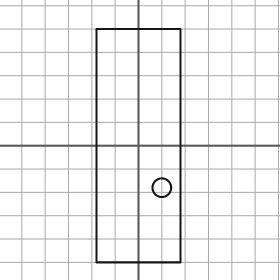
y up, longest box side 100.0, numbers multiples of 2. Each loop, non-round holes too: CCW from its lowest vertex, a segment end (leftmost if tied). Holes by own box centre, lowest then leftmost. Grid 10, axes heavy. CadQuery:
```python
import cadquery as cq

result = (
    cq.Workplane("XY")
    .moveTo(-18.0, -50.0)
    .lineTo(18.0, -50.0)
    .lineTo(18.0, 50.0)
    .lineTo(-18.0, 50.0)
    .close()
    .moveTo(10.0, -18.0)
    .circle(4.0)
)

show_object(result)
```